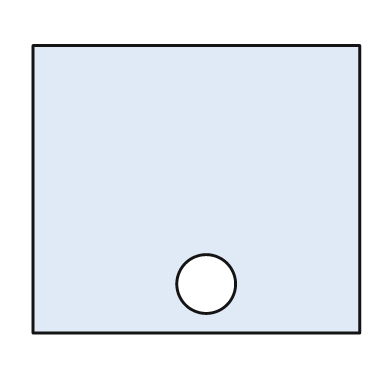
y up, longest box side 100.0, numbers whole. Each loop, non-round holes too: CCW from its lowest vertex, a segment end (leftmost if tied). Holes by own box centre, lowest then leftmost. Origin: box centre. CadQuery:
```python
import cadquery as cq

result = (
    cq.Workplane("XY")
    .moveTo(-50.0, -44.0)
    .lineTo(50.0, -44.0)
    .lineTo(50.0, 44.0)
    .lineTo(-50.0, 44.0)
    .close()
    .moveTo(3.0, -29.0)
    .circle(9.0)
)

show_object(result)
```